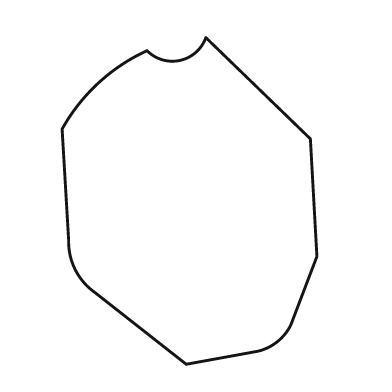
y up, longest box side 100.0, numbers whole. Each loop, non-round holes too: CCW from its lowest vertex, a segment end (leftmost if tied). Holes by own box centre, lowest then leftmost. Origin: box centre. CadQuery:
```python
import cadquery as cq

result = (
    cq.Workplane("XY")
    .moveTo(-1.0, -50.0)
    .lineTo(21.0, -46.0)
    .threePointArc((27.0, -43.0), (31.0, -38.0))
    .lineTo(39.0, -17.0)
    .lineTo(37.0, 19.0)
    .lineTo(5.0, 50.0)
    .threePointArc((-3.0, 43.0), (-13.0, 46.0))
    .threePointArc((-28.0, 36.0), (-39.0, 22.0))
    .lineTo(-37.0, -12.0)
    .threePointArc((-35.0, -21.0), (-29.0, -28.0))
    .close()
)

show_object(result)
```